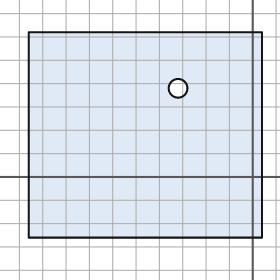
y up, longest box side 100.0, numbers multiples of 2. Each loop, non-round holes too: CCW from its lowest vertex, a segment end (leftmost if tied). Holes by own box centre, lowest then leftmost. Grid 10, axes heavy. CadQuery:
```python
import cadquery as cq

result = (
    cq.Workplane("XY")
    .moveTo(-96.0, -26.0)
    .lineTo(4.0, -26.0)
    .lineTo(4.0, 62.0)
    .lineTo(-96.0, 62.0)
    .close()
    .moveTo(-32.0, 38.0)
    .circle(4.0)
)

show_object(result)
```